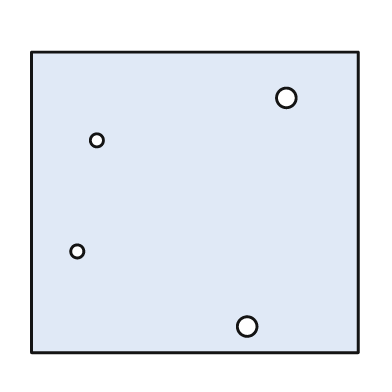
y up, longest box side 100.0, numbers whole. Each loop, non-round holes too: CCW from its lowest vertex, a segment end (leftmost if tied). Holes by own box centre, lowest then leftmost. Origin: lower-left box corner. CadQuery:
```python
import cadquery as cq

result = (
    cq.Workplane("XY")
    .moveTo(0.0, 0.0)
    .lineTo(100.0, 0.0)
    .lineTo(100.0, 92.0)
    .lineTo(0.0, 92.0)
    .close()
    .moveTo(66.0, 8.0)
    .circle(3.0)
    .moveTo(14.0, 31.0)
    .circle(2.0)
    .moveTo(20.0, 65.0)
    .circle(2.0)
    .moveTo(78.0, 78.0)
    .circle(3.0)
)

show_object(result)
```